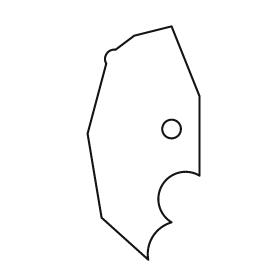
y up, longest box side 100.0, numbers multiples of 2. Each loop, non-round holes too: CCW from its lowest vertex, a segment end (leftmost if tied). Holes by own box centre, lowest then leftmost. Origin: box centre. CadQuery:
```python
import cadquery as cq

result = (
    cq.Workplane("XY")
    .moveTo(2.0, -50.0)
    .threePointArc((4.0, -40.0), (12.0, -34.0))
    .threePointArc((8.0, -18.0), (24.0, -14.0))
    .lineTo(24.0, 20.0)
    .lineTo(12.0, 50.0)
    .lineTo(-4.0, 46.0)
    .lineTo(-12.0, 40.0)
    .threePointArc((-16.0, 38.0), (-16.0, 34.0))
    .lineTo(-24.0, 4.0)
    .lineTo(-18.0, -32.0)
    .close()
    .moveTo(12.0, 6.0)
    .circle(4.0)
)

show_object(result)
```